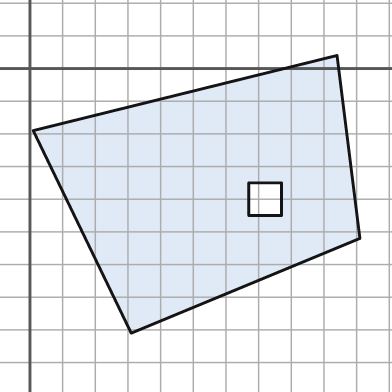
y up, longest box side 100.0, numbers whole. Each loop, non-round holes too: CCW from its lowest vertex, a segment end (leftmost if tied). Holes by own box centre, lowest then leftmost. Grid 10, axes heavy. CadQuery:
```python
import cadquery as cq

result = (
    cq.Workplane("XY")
    .moveTo(31.0, -81.0)
    .lineTo(101.0, -52.0)
    .lineTo(94.0, 4.0)
    .lineTo(1.0, -19.0)
    .close()
    .moveTo(67.0, -45.0)
    .lineTo(77.0, -45.0)
    .lineTo(77.0, -35.0)
    .lineTo(67.0, -35.0)
    .close()
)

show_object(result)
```